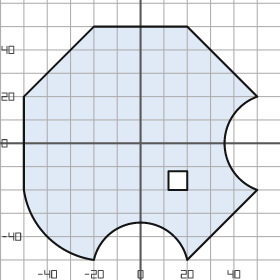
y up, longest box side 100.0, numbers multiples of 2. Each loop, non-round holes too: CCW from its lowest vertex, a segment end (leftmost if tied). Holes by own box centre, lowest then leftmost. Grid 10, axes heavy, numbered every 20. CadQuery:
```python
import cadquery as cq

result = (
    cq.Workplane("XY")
    .moveTo(-20.0, -50.0)
    .threePointArc((0.0, -34.0), (20.0, -50.0))
    .lineTo(50.0, -20.0)
    .threePointArc((36.0, 0.0), (50.0, 20.0))
    .lineTo(20.0, 50.0)
    .lineTo(-20.0, 50.0)
    .lineTo(-50.0, 20.0)
    .lineTo(-50.0, -20.0)
    .threePointArc((-40.0, -40.0), (-20.0, -50.0))
    .close()
    .moveTo(12.0, -20.0)
    .lineTo(20.0, -20.0)
    .lineTo(20.0, -12.0)
    .lineTo(12.0, -12.0)
    .close()
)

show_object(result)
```